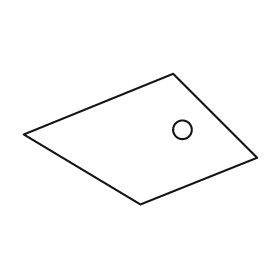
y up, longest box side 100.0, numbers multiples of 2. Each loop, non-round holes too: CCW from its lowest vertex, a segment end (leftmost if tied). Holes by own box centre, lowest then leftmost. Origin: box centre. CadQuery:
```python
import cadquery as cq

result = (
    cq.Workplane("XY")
    .moveTo(0.0, -28.0)
    .lineTo(50.0, -8.0)
    .lineTo(14.0, 28.0)
    .lineTo(-50.0, 2.0)
    .close()
    .moveTo(18.0, 4.0)
    .circle(4.0)
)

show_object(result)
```